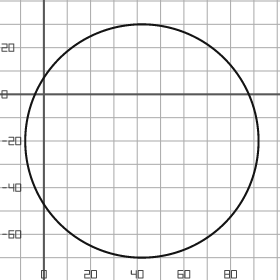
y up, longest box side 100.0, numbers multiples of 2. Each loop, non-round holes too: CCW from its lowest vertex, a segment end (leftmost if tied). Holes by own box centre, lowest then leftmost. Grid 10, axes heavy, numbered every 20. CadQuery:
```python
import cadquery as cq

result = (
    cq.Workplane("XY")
    .moveTo(42.0, -20.0)
    .circle(50.0)
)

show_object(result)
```